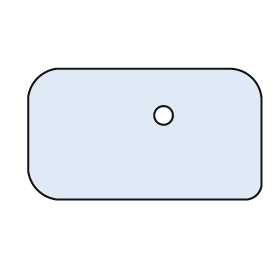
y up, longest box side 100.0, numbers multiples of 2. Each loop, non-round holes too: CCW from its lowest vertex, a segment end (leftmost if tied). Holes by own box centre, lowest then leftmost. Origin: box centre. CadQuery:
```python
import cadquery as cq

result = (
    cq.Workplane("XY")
    .moveTo(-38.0, -28.0)
    .lineTo(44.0, -28.0)
    .threePointArc((48.0, -26.0), (50.0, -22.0))
    .lineTo(50.0, 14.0)
    .threePointArc((46.0, 24.0), (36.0, 28.0))
    .lineTo(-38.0, 28.0)
    .threePointArc((-46.0, 24.0), (-50.0, 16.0))
    .lineTo(-50.0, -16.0)
    .threePointArc((-46.0, -24.0), (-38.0, -28.0))
    .close()
    .moveTo(8.0, 8.0)
    .circle(4.0)
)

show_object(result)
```